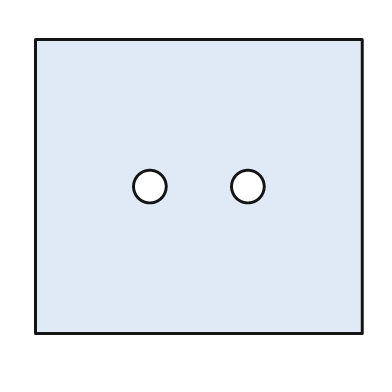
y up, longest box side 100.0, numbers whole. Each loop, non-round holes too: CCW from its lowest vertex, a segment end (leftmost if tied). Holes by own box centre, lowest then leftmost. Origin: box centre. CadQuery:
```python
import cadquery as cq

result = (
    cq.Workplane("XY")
    .moveTo(-50.0, -45.0)
    .lineTo(50.0, -45.0)
    .lineTo(50.0, 45.0)
    .lineTo(-50.0, 45.0)
    .close()
    .moveTo(-15.0, 0.0)
    .circle(5.0)
    .moveTo(15.0, 0.0)
    .circle(5.0)
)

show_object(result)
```